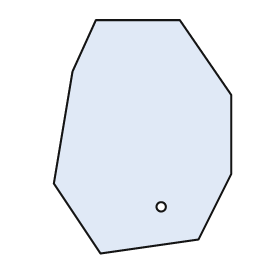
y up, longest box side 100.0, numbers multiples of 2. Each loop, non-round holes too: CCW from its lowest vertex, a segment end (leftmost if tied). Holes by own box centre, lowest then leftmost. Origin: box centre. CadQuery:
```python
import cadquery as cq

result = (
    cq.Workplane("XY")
    .moveTo(-18.0, -50.0)
    .lineTo(24.0, -44.0)
    .lineTo(38.0, -16.0)
    .lineTo(38.0, 18.0)
    .lineTo(16.0, 50.0)
    .lineTo(-20.0, 50.0)
    .lineTo(-30.0, 28.0)
    .lineTo(-38.0, -20.0)
    .close()
    .moveTo(8.0, -30.0)
    .circle(2.0)
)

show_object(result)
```